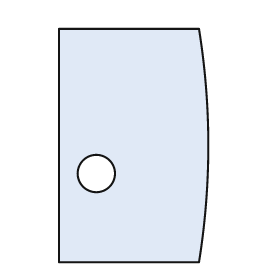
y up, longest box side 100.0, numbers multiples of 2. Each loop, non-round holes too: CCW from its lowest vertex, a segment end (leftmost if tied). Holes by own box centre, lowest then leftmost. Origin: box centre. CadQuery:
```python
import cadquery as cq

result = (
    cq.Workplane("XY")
    .moveTo(-32.0, -50.0)
    .lineTo(28.0, -50.0)
    .threePointArc((32.0, 0.0), (28.0, 50.0))
    .lineTo(-32.0, 50.0)
    .close()
    .moveTo(-16.0, -12.0)
    .circle(8.0)
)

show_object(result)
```